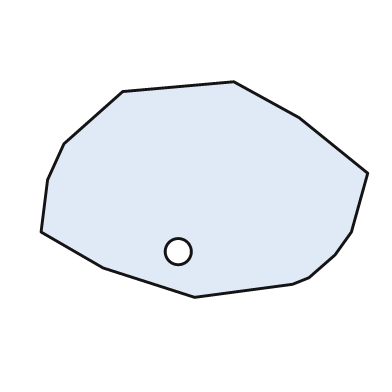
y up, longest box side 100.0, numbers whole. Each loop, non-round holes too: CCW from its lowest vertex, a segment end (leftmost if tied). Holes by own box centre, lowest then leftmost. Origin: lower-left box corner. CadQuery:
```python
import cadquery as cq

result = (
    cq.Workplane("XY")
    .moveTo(47.0, 0.0)
    .lineTo(77.0, 4.0)
    .lineTo(82.0, 6.0)
    .lineTo(90.0, 13.0)
    .lineTo(95.0, 20.0)
    .lineTo(100.0, 38.0)
    .lineTo(79.0, 55.0)
    .lineTo(59.0, 66.0)
    .lineTo(25.0, 63.0)
    .lineTo(7.0, 47.0)
    .lineTo(2.0, 36.0)
    .lineTo(0.0, 20.0)
    .lineTo(19.0, 9.0)
    .close()
    .moveTo(42.0, 14.0)
    .circle(4.0)
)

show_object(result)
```